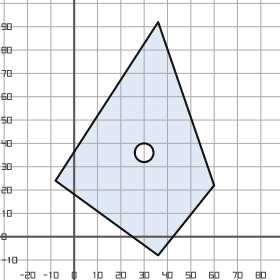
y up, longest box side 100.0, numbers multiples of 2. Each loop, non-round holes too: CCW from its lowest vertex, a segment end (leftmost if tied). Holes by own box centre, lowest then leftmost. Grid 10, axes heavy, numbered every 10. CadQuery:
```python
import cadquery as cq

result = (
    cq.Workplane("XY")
    .moveTo(36.0, -8.0)
    .lineTo(60.0, 22.0)
    .lineTo(36.0, 92.0)
    .lineTo(-8.0, 24.0)
    .close()
    .moveTo(30.0, 36.0)
    .circle(4.0)
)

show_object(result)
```